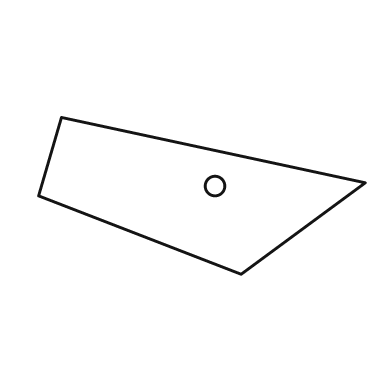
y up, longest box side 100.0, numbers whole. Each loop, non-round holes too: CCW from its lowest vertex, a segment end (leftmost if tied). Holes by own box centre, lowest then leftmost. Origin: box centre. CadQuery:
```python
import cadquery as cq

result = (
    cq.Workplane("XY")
    .moveTo(12.0, -24.0)
    .lineTo(50.0, 4.0)
    .lineTo(-43.0, 24.0)
    .lineTo(-50.0, 0.0)
    .close()
    .moveTo(4.0, 3.0)
    .circle(3.0)
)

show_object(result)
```